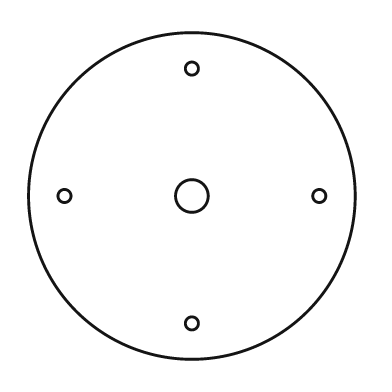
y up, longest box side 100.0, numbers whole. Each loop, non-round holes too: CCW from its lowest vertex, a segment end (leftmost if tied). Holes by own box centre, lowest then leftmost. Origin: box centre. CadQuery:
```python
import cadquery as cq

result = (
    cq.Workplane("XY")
    .moveTo(0.0, 0.0)
    .circle(50.0)
    .moveTo(0.0, -39.0)
    .circle(2.0)
    .moveTo(-39.0, 0.0)
    .circle(2.0)
    .moveTo(0.0, 0.0)
    .circle(5.0)
    .moveTo(39.0, 0.0)
    .circle(2.0)
    .moveTo(0.0, 39.0)
    .circle(2.0)
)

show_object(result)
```